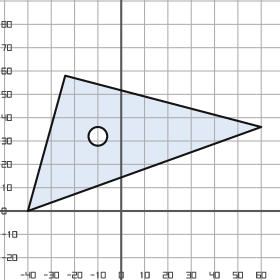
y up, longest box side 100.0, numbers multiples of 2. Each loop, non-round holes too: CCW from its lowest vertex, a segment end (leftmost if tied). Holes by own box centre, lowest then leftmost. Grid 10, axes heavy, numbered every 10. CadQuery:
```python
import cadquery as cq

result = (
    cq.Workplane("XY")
    .moveTo(-40.0, 0.0)
    .lineTo(60.0, 36.0)
    .lineTo(-24.0, 58.0)
    .close()
    .moveTo(-10.0, 32.0)
    .circle(4.0)
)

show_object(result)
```